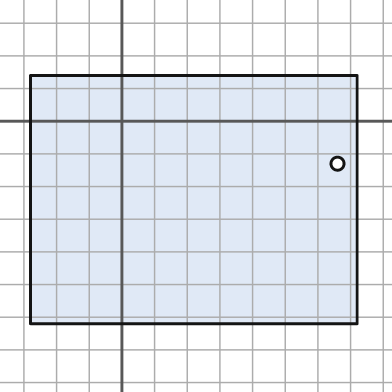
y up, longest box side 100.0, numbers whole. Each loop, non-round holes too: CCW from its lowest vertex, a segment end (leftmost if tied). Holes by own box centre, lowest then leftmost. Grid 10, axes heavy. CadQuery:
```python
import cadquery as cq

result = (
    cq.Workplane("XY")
    .moveTo(-28.0, -62.0)
    .lineTo(72.0, -62.0)
    .lineTo(72.0, 14.0)
    .lineTo(-28.0, 14.0)
    .close()
    .moveTo(66.0, -13.0)
    .circle(2.0)
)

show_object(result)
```